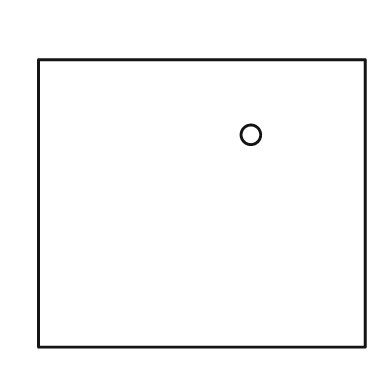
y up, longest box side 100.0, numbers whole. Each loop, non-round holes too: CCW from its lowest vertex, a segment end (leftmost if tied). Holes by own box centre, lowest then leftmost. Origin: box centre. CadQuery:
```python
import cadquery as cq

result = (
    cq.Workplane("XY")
    .moveTo(-50.0, -44.0)
    .lineTo(50.0, -44.0)
    .lineTo(50.0, 44.0)
    .lineTo(-50.0, 44.0)
    .close()
    .moveTo(15.0, 21.0)
    .circle(3.0)
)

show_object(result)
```